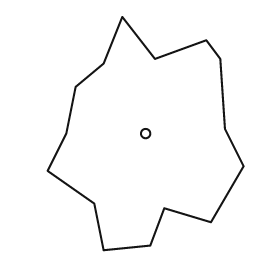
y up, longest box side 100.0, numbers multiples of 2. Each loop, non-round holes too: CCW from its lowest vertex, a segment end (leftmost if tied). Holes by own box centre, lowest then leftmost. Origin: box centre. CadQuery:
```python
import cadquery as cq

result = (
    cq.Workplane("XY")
    .moveTo(-18.0, -50.0)
    .lineTo(2.0, -48.0)
    .lineTo(8.0, -32.0)
    .lineTo(28.0, -38.0)
    .lineTo(42.0, -14.0)
    .lineTo(34.0, 2.0)
    .lineTo(32.0, 32.0)
    .lineTo(26.0, 40.0)
    .lineTo(4.0, 32.0)
    .lineTo(-10.0, 50.0)
    .lineTo(-18.0, 30.0)
    .lineTo(-30.0, 20.0)
    .lineTo(-34.0, 0.0)
    .lineTo(-42.0, -16.0)
    .lineTo(-22.0, -30.0)
    .close()
    .moveTo(0.0, 0.0)
    .circle(2.0)
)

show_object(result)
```